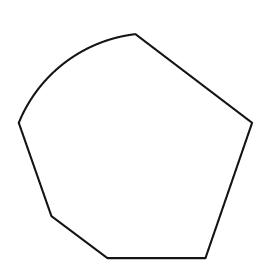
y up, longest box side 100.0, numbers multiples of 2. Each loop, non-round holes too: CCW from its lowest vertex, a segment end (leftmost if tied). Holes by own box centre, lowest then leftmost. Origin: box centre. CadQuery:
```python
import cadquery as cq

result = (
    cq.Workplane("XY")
    .moveTo(-12.0, -48.0)
    .lineTo(30.0, -48.0)
    .lineTo(50.0, 10.0)
    .lineTo(0.0, 48.0)
    .threePointArc((-30.0, 36.0), (-50.0, 10.0))
    .lineTo(-36.0, -30.0)
    .close()
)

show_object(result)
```